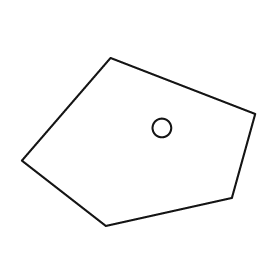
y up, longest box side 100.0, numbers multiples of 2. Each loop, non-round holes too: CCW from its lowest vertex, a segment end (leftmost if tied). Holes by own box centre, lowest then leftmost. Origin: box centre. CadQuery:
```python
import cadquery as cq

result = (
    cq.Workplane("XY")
    .moveTo(-14.0, -36.0)
    .lineTo(40.0, -24.0)
    .lineTo(50.0, 12.0)
    .lineTo(-12.0, 36.0)
    .lineTo(-50.0, -8.0)
    .close()
    .moveTo(10.0, 6.0)
    .circle(4.0)
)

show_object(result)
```